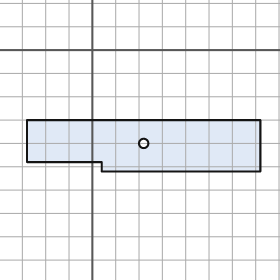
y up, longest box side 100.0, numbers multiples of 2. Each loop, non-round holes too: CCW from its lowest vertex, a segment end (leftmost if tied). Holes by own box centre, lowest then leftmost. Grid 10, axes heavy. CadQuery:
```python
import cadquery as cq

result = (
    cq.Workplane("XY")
    .moveTo(4.0, -52.0)
    .lineTo(72.0, -52.0)
    .lineTo(72.0, -30.0)
    .lineTo(-28.0, -30.0)
    .lineTo(-28.0, -48.0)
    .lineTo(4.0, -48.0)
    .close()
    .moveTo(22.0, -40.0)
    .circle(2.0)
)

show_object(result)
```